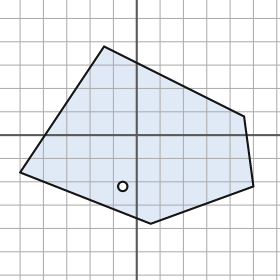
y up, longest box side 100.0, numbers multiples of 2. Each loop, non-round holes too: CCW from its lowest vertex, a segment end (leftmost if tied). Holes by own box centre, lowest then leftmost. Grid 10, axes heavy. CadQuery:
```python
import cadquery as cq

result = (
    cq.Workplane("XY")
    .moveTo(6.0, -38.0)
    .lineTo(50.0, -22.0)
    .lineTo(46.0, 8.0)
    .lineTo(-14.0, 38.0)
    .lineTo(-50.0, -16.0)
    .close()
    .moveTo(-6.0, -22.0)
    .circle(2.0)
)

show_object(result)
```